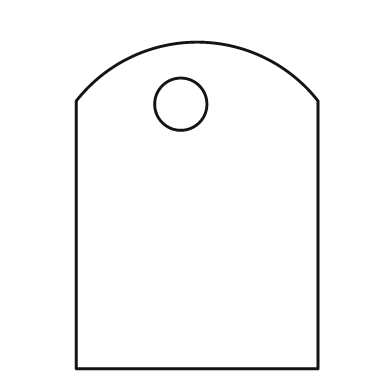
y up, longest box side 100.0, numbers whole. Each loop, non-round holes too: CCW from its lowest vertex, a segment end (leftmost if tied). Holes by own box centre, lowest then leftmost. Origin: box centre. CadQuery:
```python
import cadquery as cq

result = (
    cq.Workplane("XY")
    .moveTo(-37.0, -50.0)
    .lineTo(37.0, -50.0)
    .lineTo(37.0, 32.0)
    .threePointArc((0.0, 50.0), (-37.0, 32.0))
    .close()
    .moveTo(-5.0, 31.0)
    .circle(8.0)
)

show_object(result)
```